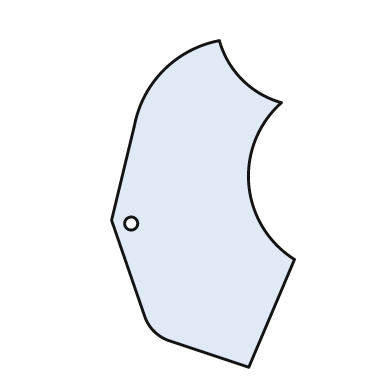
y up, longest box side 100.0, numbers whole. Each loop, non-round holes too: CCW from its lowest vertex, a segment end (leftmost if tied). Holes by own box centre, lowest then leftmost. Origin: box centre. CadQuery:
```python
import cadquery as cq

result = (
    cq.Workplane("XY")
    .moveTo(14.0, -50.0)
    .lineTo(28.0, -17.0)
    .threePointArc((14.0, 6.0), (24.0, 31.0))
    .threePointArc((12.0, 38.0), (5.0, 50.0))
    .threePointArc((-12.0, 41.0), (-21.0, 24.0))
    .lineTo(-28.0, -5.0)
    .lineTo(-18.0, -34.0)
    .threePointArc((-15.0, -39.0), (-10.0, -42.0))
    .close()
    .moveTo(-22.0, -6.0)
    .circle(2.0)
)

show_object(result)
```